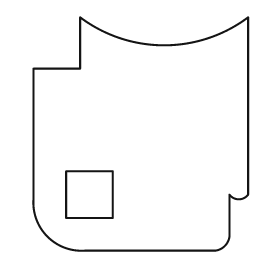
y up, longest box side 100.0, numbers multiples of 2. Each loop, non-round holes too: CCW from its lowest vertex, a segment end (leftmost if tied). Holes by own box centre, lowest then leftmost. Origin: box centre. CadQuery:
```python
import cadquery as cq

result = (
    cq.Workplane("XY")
    .moveTo(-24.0, -50.0)
    .lineTo(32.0, -50.0)
    .threePointArc((36.0, -48.0), (38.0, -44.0))
    .lineTo(38.0, -26.0)
    .threePointArc((42.0, -28.0), (46.0, -26.0))
    .lineTo(46.0, 50.0)
    .threePointArc((10.0, 38.0), (-26.0, 50.0))
    .lineTo(-26.0, 28.0)
    .lineTo(-46.0, 28.0)
    .lineTo(-46.0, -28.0)
    .threePointArc((-40.0, -44.0), (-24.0, -50.0))
    .close()
    .moveTo(-32.0, -36.0)
    .lineTo(-12.0, -36.0)
    .lineTo(-12.0, -16.0)
    .lineTo(-32.0, -16.0)
    .close()
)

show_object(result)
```